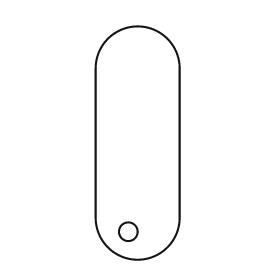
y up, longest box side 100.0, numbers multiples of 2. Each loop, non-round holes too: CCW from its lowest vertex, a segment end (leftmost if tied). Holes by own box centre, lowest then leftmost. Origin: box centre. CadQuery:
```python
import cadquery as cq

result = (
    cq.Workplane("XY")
    .moveTo(-18.0, -32.0)
    .threePointArc((0.0, -50.0), (18.0, -32.0))
    .lineTo(18.0, 32.0)
    .threePointArc((0.0, 50.0), (-18.0, 32.0))
    .close()
    .moveTo(-4.0, -38.0)
    .circle(4.0)
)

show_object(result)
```